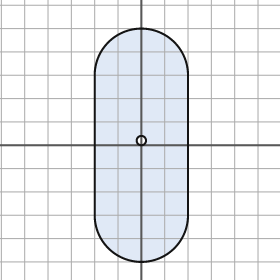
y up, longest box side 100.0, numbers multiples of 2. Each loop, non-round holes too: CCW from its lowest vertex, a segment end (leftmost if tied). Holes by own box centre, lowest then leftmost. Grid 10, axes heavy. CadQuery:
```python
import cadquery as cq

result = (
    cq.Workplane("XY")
    .moveTo(-20.0, -30.0)
    .threePointArc((0.0, -50.0), (20.0, -30.0))
    .lineTo(20.0, 30.0)
    .threePointArc((0.0, 50.0), (-20.0, 30.0))
    .close()
    .moveTo(0.0, 2.0)
    .circle(2.0)
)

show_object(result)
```